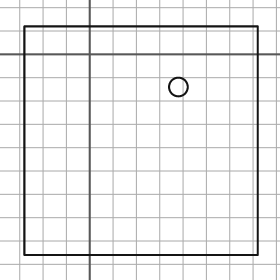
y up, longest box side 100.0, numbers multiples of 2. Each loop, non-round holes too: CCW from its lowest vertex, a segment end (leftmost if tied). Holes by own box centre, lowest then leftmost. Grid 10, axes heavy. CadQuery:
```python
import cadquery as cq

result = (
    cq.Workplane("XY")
    .moveTo(-28.0, -86.0)
    .lineTo(72.0, -86.0)
    .lineTo(72.0, 12.0)
    .lineTo(-28.0, 12.0)
    .close()
    .moveTo(38.0, -14.0)
    .circle(4.0)
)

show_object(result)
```